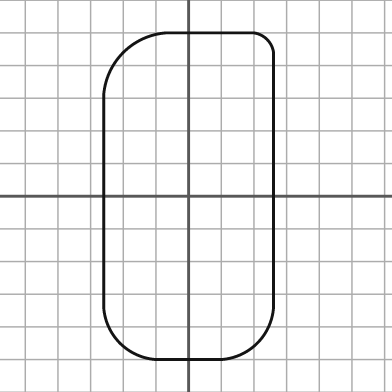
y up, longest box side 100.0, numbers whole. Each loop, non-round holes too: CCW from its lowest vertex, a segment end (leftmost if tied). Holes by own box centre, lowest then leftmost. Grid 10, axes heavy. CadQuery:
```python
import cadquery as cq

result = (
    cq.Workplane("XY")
    .moveTo(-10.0, -50.0)
    .lineTo(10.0, -50.0)
    .threePointArc((21.0, -45.0), (26.0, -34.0))
    .lineTo(26.0, 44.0)
    .threePointArc((24.0, 48.0), (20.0, 50.0))
    .lineTo(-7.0, 50.0)
    .threePointArc((-20.0, 44.0), (-26.0, 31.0))
    .lineTo(-26.0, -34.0)
    .threePointArc((-21.0, -45.0), (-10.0, -50.0))
    .close()
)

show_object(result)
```